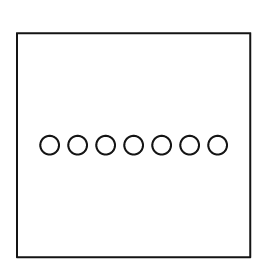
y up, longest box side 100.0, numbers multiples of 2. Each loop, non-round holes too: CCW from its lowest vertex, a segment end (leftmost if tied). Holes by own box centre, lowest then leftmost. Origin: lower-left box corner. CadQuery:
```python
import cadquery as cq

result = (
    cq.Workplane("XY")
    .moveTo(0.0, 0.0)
    .lineTo(100.0, 0.0)
    .lineTo(100.0, 96.0)
    .lineTo(0.0, 96.0)
    .close()
    .moveTo(14.0, 48.0)
    .circle(4.0)
    .moveTo(26.0, 48.0)
    .circle(4.0)
    .moveTo(38.0, 48.0)
    .circle(4.0)
    .moveTo(50.0, 48.0)
    .circle(4.0)
    .moveTo(62.0, 48.0)
    .circle(4.0)
    .moveTo(74.0, 48.0)
    .circle(4.0)
    .moveTo(86.0, 48.0)
    .circle(4.0)
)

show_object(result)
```